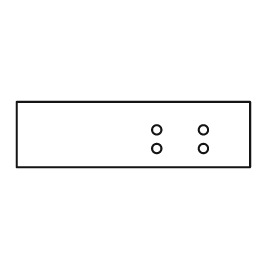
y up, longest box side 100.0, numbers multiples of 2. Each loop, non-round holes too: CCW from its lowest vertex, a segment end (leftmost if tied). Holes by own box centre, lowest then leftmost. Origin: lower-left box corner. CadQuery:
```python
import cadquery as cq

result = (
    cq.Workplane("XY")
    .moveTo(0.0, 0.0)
    .lineTo(100.0, 0.0)
    .lineTo(100.0, 28.0)
    .lineTo(0.0, 28.0)
    .close()
    .moveTo(60.0, 8.0)
    .circle(2.0)
    .moveTo(80.0, 8.0)
    .circle(2.0)
    .moveTo(60.0, 16.0)
    .circle(2.0)
    .moveTo(80.0, 16.0)
    .circle(2.0)
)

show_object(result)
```